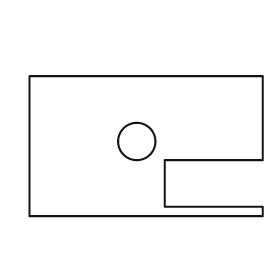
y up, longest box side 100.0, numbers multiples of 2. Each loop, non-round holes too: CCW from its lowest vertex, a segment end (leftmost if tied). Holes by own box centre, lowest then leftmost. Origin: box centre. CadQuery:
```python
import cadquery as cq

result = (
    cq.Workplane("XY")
    .moveTo(-50.0, -30.0)
    .lineTo(50.0, -30.0)
    .lineTo(50.0, -26.0)
    .lineTo(8.0, -26.0)
    .lineTo(8.0, -6.0)
    .lineTo(50.0, -6.0)
    .lineTo(50.0, 30.0)
    .lineTo(-50.0, 30.0)
    .close()
    .moveTo(-4.0, 2.0)
    .circle(8.0)
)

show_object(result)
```